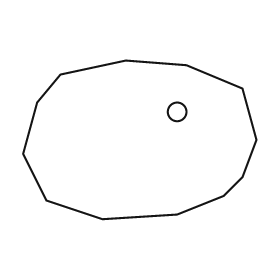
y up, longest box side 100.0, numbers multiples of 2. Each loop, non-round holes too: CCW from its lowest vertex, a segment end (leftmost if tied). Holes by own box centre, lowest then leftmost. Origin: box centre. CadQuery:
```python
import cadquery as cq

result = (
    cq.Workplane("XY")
    .moveTo(-16.0, -34.0)
    .lineTo(16.0, -32.0)
    .lineTo(36.0, -24.0)
    .lineTo(44.0, -16.0)
    .lineTo(50.0, 0.0)
    .lineTo(44.0, 22.0)
    .lineTo(20.0, 32.0)
    .lineTo(-6.0, 34.0)
    .lineTo(-34.0, 28.0)
    .lineTo(-44.0, 16.0)
    .lineTo(-50.0, -6.0)
    .lineTo(-40.0, -26.0)
    .close()
    .moveTo(16.0, 12.0)
    .circle(4.0)
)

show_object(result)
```